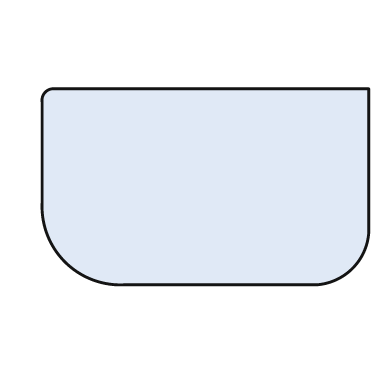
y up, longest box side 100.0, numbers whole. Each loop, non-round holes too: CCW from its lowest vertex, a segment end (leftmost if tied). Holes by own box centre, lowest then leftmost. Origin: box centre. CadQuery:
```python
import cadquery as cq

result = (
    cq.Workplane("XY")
    .moveTo(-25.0, -30.0)
    .lineTo(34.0, -30.0)
    .threePointArc((45.0, -25.0), (50.0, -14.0))
    .lineTo(50.0, 30.0)
    .lineTo(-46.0, 30.0)
    .threePointArc((-49.0, 29.0), (-50.0, 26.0))
    .lineTo(-50.0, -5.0)
    .threePointArc((-43.0, -23.0), (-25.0, -30.0))
    .close()
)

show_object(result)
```